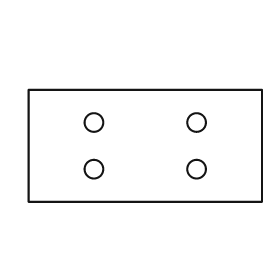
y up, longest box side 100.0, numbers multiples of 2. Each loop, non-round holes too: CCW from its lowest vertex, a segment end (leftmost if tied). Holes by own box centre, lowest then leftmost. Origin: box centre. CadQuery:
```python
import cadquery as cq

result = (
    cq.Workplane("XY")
    .moveTo(-50.0, -24.0)
    .lineTo(50.0, -24.0)
    .lineTo(50.0, 24.0)
    .lineTo(-50.0, 24.0)
    .close()
    .moveTo(-22.0, -10.0)
    .circle(4.0)
    .moveTo(22.0, -10.0)
    .circle(4.0)
    .moveTo(-22.0, 10.0)
    .circle(4.0)
    .moveTo(22.0, 10.0)
    .circle(4.0)
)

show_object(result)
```